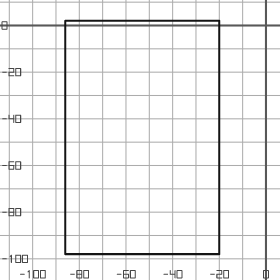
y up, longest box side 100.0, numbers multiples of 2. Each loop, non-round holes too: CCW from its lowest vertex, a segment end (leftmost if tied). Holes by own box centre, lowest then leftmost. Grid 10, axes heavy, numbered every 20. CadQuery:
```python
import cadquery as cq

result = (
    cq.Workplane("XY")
    .moveTo(-86.0, -98.0)
    .lineTo(-20.0, -98.0)
    .lineTo(-20.0, 2.0)
    .lineTo(-86.0, 2.0)
    .close()
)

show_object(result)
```